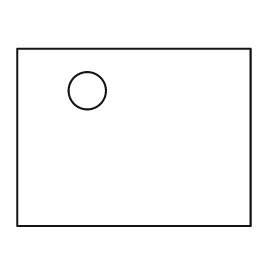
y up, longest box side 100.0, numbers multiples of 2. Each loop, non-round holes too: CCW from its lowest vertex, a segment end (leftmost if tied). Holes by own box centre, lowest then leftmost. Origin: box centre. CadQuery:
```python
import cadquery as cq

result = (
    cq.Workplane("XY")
    .moveTo(-50.0, -38.0)
    .lineTo(50.0, -38.0)
    .lineTo(50.0, 38.0)
    .lineTo(-50.0, 38.0)
    .close()
    .moveTo(-20.0, 20.0)
    .circle(8.0)
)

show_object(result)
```